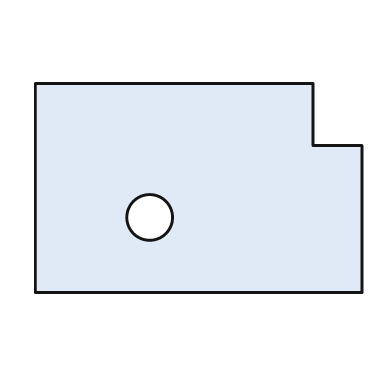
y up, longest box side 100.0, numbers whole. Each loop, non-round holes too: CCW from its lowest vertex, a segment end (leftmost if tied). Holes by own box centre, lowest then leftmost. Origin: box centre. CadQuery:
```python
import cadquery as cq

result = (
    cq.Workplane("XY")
    .moveTo(-50.0, -32.0)
    .lineTo(50.0, -32.0)
    .lineTo(50.0, 13.0)
    .lineTo(35.0, 13.0)
    .lineTo(35.0, 32.0)
    .lineTo(-50.0, 32.0)
    .close()
    .moveTo(-15.0, -9.0)
    .circle(7.0)
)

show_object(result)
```